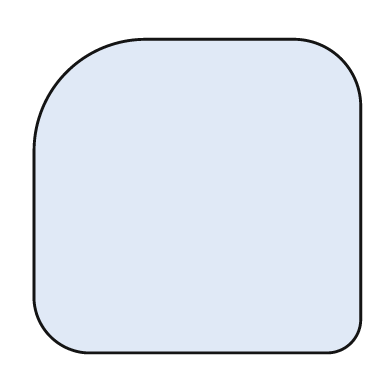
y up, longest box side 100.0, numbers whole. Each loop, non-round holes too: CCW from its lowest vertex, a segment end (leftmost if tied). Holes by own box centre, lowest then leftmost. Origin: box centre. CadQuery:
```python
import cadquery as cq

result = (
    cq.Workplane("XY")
    .moveTo(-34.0, -48.0)
    .lineTo(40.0, -48.0)
    .threePointArc((47.0, -45.0), (50.0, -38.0))
    .lineTo(50.0, 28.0)
    .threePointArc((44.0, 42.0), (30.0, 48.0))
    .lineTo(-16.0, 48.0)
    .threePointArc((-40.0, 38.0), (-50.0, 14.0))
    .lineTo(-50.0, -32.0)
    .threePointArc((-45.0, -43.0), (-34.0, -48.0))
    .close()
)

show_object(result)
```